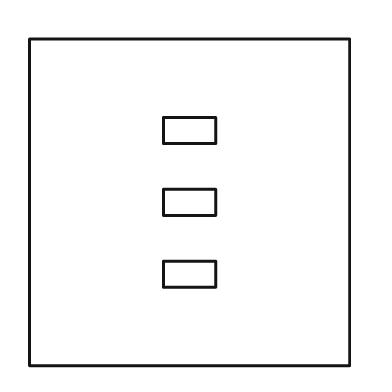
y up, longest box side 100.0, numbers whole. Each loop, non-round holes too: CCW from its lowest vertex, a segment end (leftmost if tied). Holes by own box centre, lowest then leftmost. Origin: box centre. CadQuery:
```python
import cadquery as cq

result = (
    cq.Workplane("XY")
    .moveTo(-49.0, -50.0)
    .lineTo(49.0, -50.0)
    .lineTo(49.0, 50.0)
    .lineTo(-49.0, 50.0)
    .close()
    .moveTo(-8.0, -26.0)
    .lineTo(8.0, -26.0)
    .lineTo(8.0, -18.0)
    .lineTo(-8.0, -18.0)
    .close()
    .moveTo(-8.0, -4.0)
    .lineTo(8.0, -4.0)
    .lineTo(8.0, 4.0)
    .lineTo(-8.0, 4.0)
    .close()
    .moveTo(-8.0, 18.0)
    .lineTo(8.0, 18.0)
    .lineTo(8.0, 26.0)
    .lineTo(-8.0, 26.0)
    .close()
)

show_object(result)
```